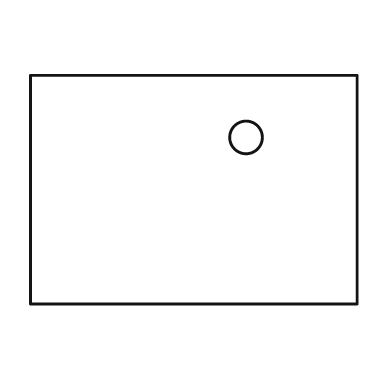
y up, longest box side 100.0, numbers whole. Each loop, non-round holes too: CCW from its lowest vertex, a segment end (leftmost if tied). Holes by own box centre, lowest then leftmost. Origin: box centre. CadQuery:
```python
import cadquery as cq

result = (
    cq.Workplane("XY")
    .moveTo(-50.0, -35.0)
    .lineTo(50.0, -35.0)
    .lineTo(50.0, 35.0)
    .lineTo(-50.0, 35.0)
    .close()
    .moveTo(16.0, 16.0)
    .circle(5.0)
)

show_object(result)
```